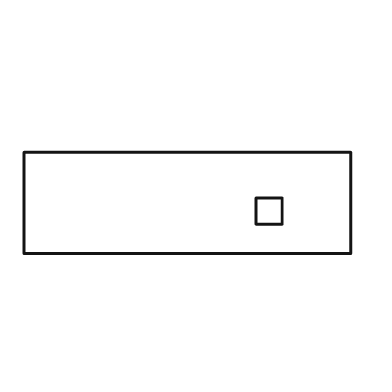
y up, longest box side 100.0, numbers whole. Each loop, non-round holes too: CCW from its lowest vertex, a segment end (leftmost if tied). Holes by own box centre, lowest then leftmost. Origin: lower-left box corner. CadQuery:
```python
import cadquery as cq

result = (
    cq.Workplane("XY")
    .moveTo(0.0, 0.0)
    .lineTo(100.0, 0.0)
    .lineTo(100.0, 31.0)
    .lineTo(0.0, 31.0)
    .close()
    .moveTo(71.0, 9.0)
    .lineTo(79.0, 9.0)
    .lineTo(79.0, 17.0)
    .lineTo(71.0, 17.0)
    .close()
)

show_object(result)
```